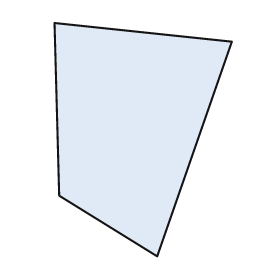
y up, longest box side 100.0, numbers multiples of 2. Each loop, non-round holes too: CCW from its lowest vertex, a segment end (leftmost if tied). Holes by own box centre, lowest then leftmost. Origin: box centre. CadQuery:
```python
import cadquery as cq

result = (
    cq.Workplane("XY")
    .moveTo(6.0, -50.0)
    .lineTo(38.0, 42.0)
    .lineTo(-38.0, 50.0)
    .lineTo(-36.0, -24.0)
    .close()
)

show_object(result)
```